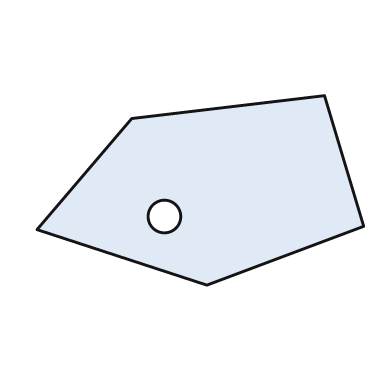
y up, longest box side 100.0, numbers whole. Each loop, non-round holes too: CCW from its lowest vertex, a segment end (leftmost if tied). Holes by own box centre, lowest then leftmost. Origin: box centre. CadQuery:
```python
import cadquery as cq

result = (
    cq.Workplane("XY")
    .moveTo(2.0, -29.0)
    .lineTo(50.0, -11.0)
    .lineTo(38.0, 29.0)
    .lineTo(-21.0, 22.0)
    .lineTo(-50.0, -12.0)
    .close()
    .moveTo(-11.0, -8.0)
    .circle(5.0)
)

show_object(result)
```